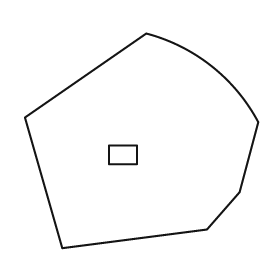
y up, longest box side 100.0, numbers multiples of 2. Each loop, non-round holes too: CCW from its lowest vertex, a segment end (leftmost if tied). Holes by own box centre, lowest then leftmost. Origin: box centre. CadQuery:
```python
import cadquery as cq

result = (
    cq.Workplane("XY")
    .moveTo(-34.0, -46.0)
    .lineTo(28.0, -38.0)
    .lineTo(42.0, -22.0)
    .lineTo(50.0, 8.0)
    .threePointArc((30.0, 32.0), (2.0, 46.0))
    .lineTo(-50.0, 10.0)
    .close()
    .moveTo(-14.0, -10.0)
    .lineTo(-2.0, -10.0)
    .lineTo(-2.0, -2.0)
    .lineTo(-14.0, -2.0)
    .close()
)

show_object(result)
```